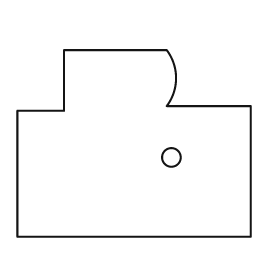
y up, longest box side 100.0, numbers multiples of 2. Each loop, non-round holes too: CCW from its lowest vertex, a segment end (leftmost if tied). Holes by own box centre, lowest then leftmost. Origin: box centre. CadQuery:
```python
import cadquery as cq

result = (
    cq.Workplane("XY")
    .moveTo(-50.0, -40.0)
    .lineTo(50.0, -40.0)
    .lineTo(50.0, 16.0)
    .lineTo(14.0, 16.0)
    .threePointArc((18.0, 28.0), (14.0, 40.0))
    .lineTo(-30.0, 40.0)
    .lineTo(-30.0, 14.0)
    .lineTo(-50.0, 14.0)
    .close()
    .moveTo(16.0, -6.0)
    .circle(4.0)
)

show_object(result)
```